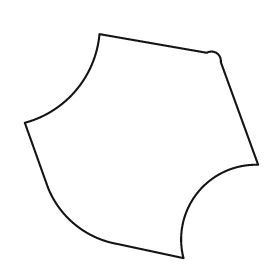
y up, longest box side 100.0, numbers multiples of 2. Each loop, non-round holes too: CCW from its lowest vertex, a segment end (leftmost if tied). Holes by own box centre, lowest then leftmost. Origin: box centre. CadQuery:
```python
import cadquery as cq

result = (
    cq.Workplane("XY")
    .moveTo(18.0, -48.0)
    .threePointArc((24.0, -20.0), (50.0, -8.0))
    .lineTo(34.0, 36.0)
    .threePointArc((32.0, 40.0), (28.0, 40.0))
    .lineTo(-18.0, 48.0)
    .threePointArc((-28.0, 24.0), (-50.0, 10.0))
    .lineTo(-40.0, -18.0)
    .threePointArc((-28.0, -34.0), (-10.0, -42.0))
    .close()
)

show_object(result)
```